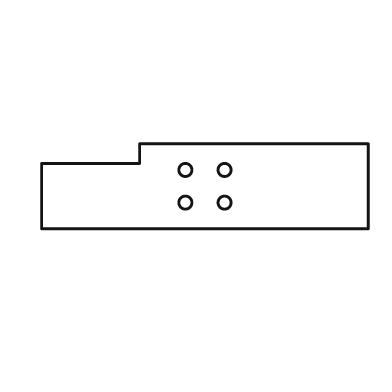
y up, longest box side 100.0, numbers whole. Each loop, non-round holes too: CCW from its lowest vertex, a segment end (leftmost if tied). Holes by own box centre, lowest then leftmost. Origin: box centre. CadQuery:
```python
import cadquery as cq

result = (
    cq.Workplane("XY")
    .moveTo(-50.0, -13.0)
    .lineTo(50.0, -13.0)
    .lineTo(50.0, 13.0)
    .lineTo(-20.0, 13.0)
    .lineTo(-20.0, 7.0)
    .lineTo(-50.0, 7.0)
    .close()
    .moveTo(-6.0, -5.0)
    .circle(2.0)
    .moveTo(6.0, -5.0)
    .circle(2.0)
    .moveTo(-6.0, 5.0)
    .circle(2.0)
    .moveTo(6.0, 5.0)
    .circle(2.0)
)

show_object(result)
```